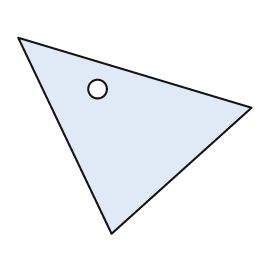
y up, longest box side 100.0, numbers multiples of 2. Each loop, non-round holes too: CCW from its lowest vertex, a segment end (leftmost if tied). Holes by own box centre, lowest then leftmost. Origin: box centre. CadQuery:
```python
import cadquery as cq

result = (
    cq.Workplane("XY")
    .moveTo(-10.0, -42.0)
    .lineTo(50.0, 12.0)
    .lineTo(-50.0, 42.0)
    .close()
    .moveTo(-16.0, 20.0)
    .circle(4.0)
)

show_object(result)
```